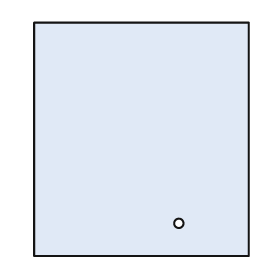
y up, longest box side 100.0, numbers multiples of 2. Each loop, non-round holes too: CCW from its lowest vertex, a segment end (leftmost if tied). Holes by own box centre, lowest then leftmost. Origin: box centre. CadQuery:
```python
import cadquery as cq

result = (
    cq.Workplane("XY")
    .moveTo(-46.0, -50.0)
    .lineTo(46.0, -50.0)
    .lineTo(46.0, 50.0)
    .lineTo(-46.0, 50.0)
    .close()
    .moveTo(16.0, -36.0)
    .circle(2.0)
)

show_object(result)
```